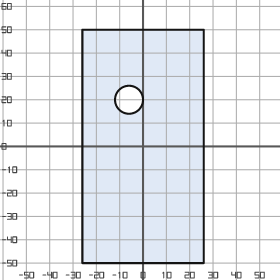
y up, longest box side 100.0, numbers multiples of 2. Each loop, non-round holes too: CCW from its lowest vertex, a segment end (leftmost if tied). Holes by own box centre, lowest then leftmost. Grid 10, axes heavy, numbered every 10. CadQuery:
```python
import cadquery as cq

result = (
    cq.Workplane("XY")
    .moveTo(-26.0, -50.0)
    .lineTo(26.0, -50.0)
    .lineTo(26.0, 50.0)
    .lineTo(-26.0, 50.0)
    .close()
    .moveTo(-6.0, 20.0)
    .circle(6.0)
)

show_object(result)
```